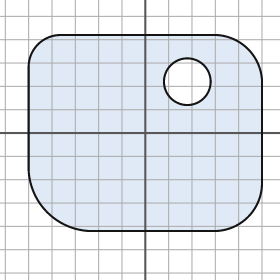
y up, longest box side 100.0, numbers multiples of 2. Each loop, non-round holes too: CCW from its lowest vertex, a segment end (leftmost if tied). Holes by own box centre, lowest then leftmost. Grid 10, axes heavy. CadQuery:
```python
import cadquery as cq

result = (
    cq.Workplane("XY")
    .moveTo(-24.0, -42.0)
    .lineTo(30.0, -42.0)
    .threePointArc((44.0, -36.0), (50.0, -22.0))
    .lineTo(50.0, 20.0)
    .threePointArc((44.0, 36.0), (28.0, 42.0))
    .lineTo(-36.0, 42.0)
    .threePointArc((-46.0, 38.0), (-50.0, 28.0))
    .lineTo(-50.0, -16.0)
    .threePointArc((-42.0, -34.0), (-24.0, -42.0))
    .close()
    .moveTo(18.0, 22.0)
    .circle(10.0)
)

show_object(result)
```